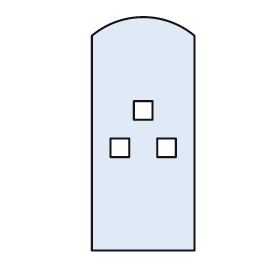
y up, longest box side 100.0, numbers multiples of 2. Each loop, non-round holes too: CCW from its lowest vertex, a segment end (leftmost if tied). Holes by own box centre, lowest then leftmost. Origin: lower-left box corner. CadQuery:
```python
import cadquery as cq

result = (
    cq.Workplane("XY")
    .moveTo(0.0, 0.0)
    .lineTo(44.0, 0.0)
    .lineTo(44.0, 92.0)
    .threePointArc((22.0, 100.0), (0.0, 92.0))
    .close()
    .moveTo(8.0, 40.0)
    .lineTo(16.0, 40.0)
    .lineTo(16.0, 48.0)
    .lineTo(8.0, 48.0)
    .close()
    .moveTo(28.0, 40.0)
    .lineTo(36.0, 40.0)
    .lineTo(36.0, 48.0)
    .lineTo(28.0, 48.0)
    .close()
    .moveTo(18.0, 56.0)
    .lineTo(26.0, 56.0)
    .lineTo(26.0, 64.0)
    .lineTo(18.0, 64.0)
    .close()
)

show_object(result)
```